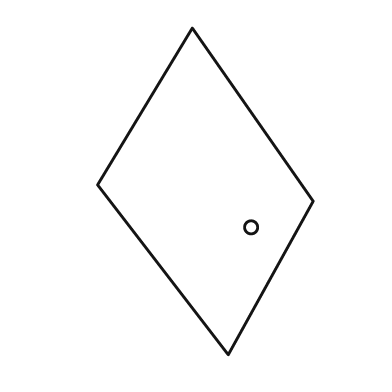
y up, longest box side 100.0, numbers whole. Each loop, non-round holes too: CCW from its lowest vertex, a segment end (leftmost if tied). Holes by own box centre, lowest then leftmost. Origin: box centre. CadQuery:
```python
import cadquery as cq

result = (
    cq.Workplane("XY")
    .moveTo(7.0, -50.0)
    .lineTo(33.0, -3.0)
    .lineTo(-4.0, 50.0)
    .lineTo(-33.0, 2.0)
    .close()
    .moveTo(14.0, -11.0)
    .circle(2.0)
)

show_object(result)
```